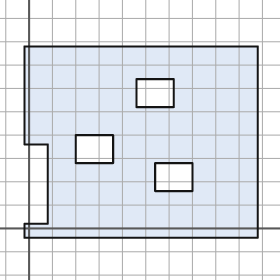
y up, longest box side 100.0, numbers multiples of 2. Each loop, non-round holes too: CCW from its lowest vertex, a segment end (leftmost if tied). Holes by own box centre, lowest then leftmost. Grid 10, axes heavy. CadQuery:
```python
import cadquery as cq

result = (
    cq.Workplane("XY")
    .moveTo(-2.0, -4.0)
    .lineTo(98.0, -4.0)
    .lineTo(98.0, 78.0)
    .lineTo(-2.0, 78.0)
    .lineTo(-2.0, 36.0)
    .lineTo(8.0, 36.0)
    .lineTo(8.0, 2.0)
    .lineTo(-2.0, 2.0)
    .close()
    .moveTo(54.0, 16.0)
    .lineTo(70.0, 16.0)
    .lineTo(70.0, 28.0)
    .lineTo(54.0, 28.0)
    .close()
    .moveTo(20.0, 28.0)
    .lineTo(36.0, 28.0)
    .lineTo(36.0, 40.0)
    .lineTo(20.0, 40.0)
    .close()
    .moveTo(46.0, 52.0)
    .lineTo(62.0, 52.0)
    .lineTo(62.0, 64.0)
    .lineTo(46.0, 64.0)
    .close()
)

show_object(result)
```